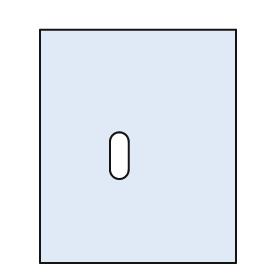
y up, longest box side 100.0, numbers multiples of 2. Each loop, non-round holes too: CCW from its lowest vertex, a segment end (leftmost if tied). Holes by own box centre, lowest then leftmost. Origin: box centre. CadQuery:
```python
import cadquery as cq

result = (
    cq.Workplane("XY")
    .moveTo(-42.0, -50.0)
    .lineTo(42.0, -50.0)
    .lineTo(42.0, 50.0)
    .lineTo(-42.0, 50.0)
    .close()
    .moveTo(-12.0, -10.0)
    .threePointArc((-8.0, -14.0), (-4.0, -10.0))
    .lineTo(-4.0, 2.0)
    .threePointArc((-8.0, 6.0), (-12.0, 2.0))
    .close()
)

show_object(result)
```